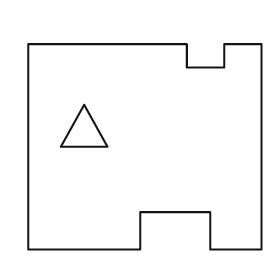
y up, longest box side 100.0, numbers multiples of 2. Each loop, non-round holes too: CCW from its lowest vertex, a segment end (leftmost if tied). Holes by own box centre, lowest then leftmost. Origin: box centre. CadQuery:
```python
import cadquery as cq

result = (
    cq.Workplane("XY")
    .moveTo(-50.0, -44.0)
    .lineTo(-2.0, -44.0)
    .lineTo(-2.0, -28.0)
    .lineTo(28.0, -28.0)
    .lineTo(28.0, -44.0)
    .lineTo(50.0, -44.0)
    .lineTo(50.0, 44.0)
    .lineTo(34.0, 44.0)
    .lineTo(34.0, 34.0)
    .lineTo(18.0, 34.0)
    .lineTo(18.0, 44.0)
    .lineTo(-50.0, 44.0)
    .close()
    .moveTo(-36.0, 0.0)
    .lineTo(-16.0, 0.0)
    .lineTo(-26.0, 18.0)
    .close()
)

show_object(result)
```